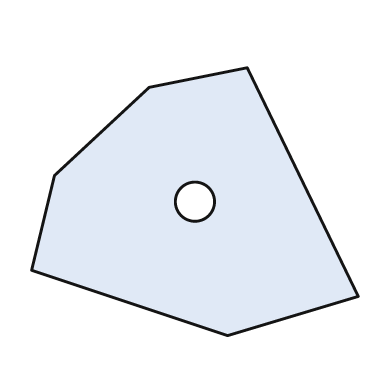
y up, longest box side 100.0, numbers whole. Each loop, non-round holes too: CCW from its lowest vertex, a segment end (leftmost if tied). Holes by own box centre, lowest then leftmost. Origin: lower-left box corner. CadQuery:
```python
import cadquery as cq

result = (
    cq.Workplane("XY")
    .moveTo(60.0, 0.0)
    .lineTo(100.0, 12.0)
    .lineTo(66.0, 82.0)
    .lineTo(36.0, 76.0)
    .lineTo(7.0, 49.0)
    .lineTo(0.0, 20.0)
    .close()
    .moveTo(50.0, 41.0)
    .circle(6.0)
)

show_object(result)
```